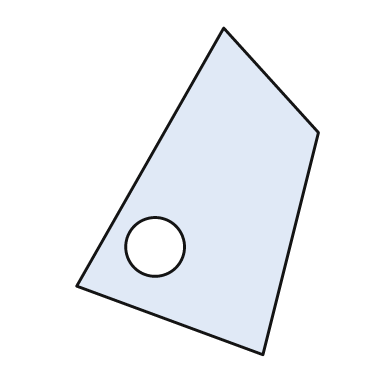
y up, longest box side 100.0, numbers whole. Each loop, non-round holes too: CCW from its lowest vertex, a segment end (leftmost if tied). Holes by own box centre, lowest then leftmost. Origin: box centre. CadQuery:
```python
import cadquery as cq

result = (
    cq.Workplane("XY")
    .moveTo(20.0, -50.0)
    .lineTo(37.0, 18.0)
    .lineTo(8.0, 50.0)
    .lineTo(-37.0, -29.0)
    .close()
    .moveTo(-13.0, -17.0)
    .circle(9.0)
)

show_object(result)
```